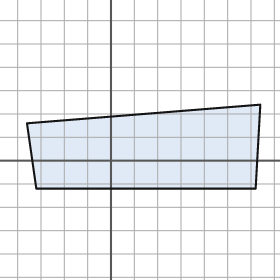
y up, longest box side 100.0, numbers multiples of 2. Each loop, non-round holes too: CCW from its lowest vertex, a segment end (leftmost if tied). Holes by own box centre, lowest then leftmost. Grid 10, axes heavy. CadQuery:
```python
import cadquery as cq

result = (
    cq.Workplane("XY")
    .moveTo(-32.0, -12.0)
    .lineTo(62.0, -12.0)
    .lineTo(64.0, 24.0)
    .lineTo(-36.0, 16.0)
    .close()
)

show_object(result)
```